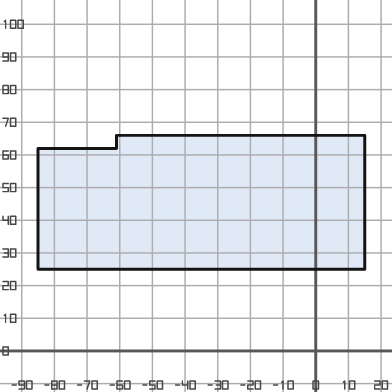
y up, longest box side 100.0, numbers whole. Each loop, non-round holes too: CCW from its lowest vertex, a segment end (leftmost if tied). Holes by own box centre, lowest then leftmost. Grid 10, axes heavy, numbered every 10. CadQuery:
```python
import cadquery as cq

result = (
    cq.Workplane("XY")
    .moveTo(-85.0, 25.0)
    .lineTo(15.0, 25.0)
    .lineTo(15.0, 66.0)
    .lineTo(-61.0, 66.0)
    .lineTo(-61.0, 62.0)
    .lineTo(-85.0, 62.0)
    .close()
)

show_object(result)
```